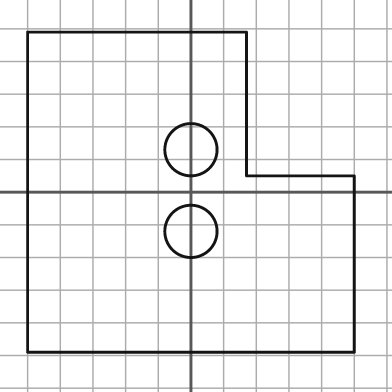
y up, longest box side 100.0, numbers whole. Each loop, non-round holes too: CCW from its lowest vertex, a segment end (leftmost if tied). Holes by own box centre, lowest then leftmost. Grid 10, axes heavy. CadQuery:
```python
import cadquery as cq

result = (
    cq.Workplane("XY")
    .moveTo(-50.0, -49.0)
    .lineTo(50.0, -49.0)
    .lineTo(50.0, 5.0)
    .lineTo(17.0, 5.0)
    .lineTo(17.0, 49.0)
    .lineTo(-50.0, 49.0)
    .close()
    .moveTo(0.0, -12.0)
    .circle(8.0)
    .moveTo(0.0, 13.0)
    .circle(8.0)
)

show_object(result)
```